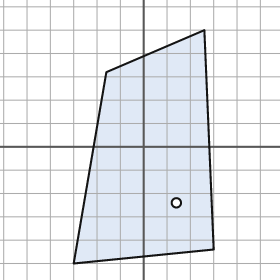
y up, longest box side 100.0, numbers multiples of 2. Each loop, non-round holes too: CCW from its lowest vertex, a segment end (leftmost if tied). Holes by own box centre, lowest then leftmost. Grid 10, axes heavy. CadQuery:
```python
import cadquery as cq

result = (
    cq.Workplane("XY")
    .moveTo(-30.0, -50.0)
    .lineTo(30.0, -44.0)
    .lineTo(26.0, 50.0)
    .lineTo(-16.0, 32.0)
    .close()
    .moveTo(14.0, -24.0)
    .circle(2.0)
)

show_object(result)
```